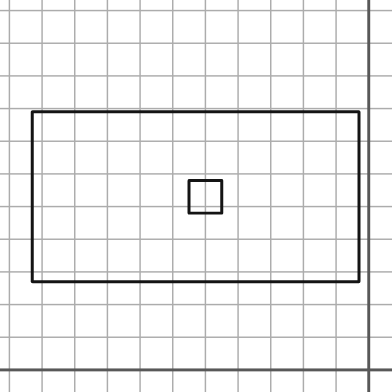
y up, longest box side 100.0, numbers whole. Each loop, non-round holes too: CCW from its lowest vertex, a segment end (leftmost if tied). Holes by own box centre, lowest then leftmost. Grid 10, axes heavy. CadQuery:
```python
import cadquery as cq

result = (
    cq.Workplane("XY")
    .moveTo(-103.0, 27.0)
    .lineTo(-3.0, 27.0)
    .lineTo(-3.0, 79.0)
    .lineTo(-103.0, 79.0)
    .close()
    .moveTo(-55.0, 48.0)
    .lineTo(-45.0, 48.0)
    .lineTo(-45.0, 58.0)
    .lineTo(-55.0, 58.0)
    .close()
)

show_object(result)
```